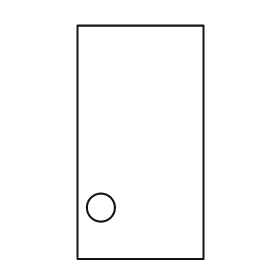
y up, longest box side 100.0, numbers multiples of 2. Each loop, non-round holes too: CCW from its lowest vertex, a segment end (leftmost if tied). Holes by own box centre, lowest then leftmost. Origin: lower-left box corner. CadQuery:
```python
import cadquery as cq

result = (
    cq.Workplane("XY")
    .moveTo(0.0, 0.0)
    .lineTo(54.0, 0.0)
    .lineTo(54.0, 100.0)
    .lineTo(0.0, 100.0)
    .close()
    .moveTo(10.0, 22.0)
    .circle(6.0)
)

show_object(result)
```